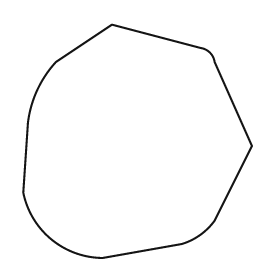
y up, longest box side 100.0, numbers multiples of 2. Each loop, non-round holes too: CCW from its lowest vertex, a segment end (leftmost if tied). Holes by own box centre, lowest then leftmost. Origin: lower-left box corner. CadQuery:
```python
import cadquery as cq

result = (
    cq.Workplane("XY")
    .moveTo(34.0, 0.0)
    .lineTo(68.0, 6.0)
    .threePointArc((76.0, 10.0), (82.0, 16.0))
    .lineTo(98.0, 48.0)
    .lineTo(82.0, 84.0)
    .threePointArc((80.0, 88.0), (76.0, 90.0))
    .lineTo(38.0, 100.0)
    .lineTo(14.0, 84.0)
    .threePointArc((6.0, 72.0), (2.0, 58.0))
    .lineTo(0.0, 28.0)
    .threePointArc((12.0, 8.0), (34.0, 0.0))
    .close()
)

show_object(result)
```